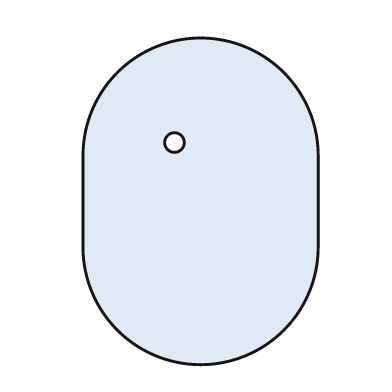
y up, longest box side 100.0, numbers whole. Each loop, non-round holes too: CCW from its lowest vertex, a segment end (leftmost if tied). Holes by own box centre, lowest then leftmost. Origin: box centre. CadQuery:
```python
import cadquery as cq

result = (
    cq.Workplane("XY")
    .moveTo(-36.0, -14.0)
    .threePointArc((0.0, -50.0), (36.0, -14.0))
    .lineTo(36.0, 14.0)
    .threePointArc((0.0, 50.0), (-36.0, 14.0))
    .close()
    .moveTo(-8.0, 18.0)
    .circle(3.0)
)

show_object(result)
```